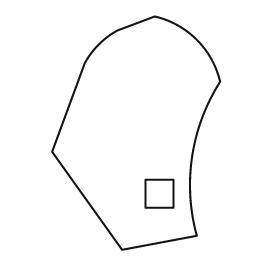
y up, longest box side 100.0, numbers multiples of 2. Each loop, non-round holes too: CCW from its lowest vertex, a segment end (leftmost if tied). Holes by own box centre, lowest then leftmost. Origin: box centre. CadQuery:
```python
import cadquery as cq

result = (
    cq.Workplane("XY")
    .moveTo(-6.0, -50.0)
    .lineTo(26.0, -44.0)
    .threePointArc((24.0, -10.0), (36.0, 22.0))
    .threePointArc((26.0, 40.0), (8.0, 50.0))
    .lineTo(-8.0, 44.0)
    .threePointArc((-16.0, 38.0), (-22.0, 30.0))
    .lineTo(-36.0, -8.0)
    .close()
    .moveTo(4.0, -32.0)
    .lineTo(16.0, -32.0)
    .lineTo(16.0, -20.0)
    .lineTo(4.0, -20.0)
    .close()
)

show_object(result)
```